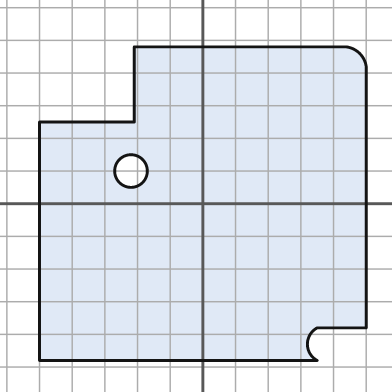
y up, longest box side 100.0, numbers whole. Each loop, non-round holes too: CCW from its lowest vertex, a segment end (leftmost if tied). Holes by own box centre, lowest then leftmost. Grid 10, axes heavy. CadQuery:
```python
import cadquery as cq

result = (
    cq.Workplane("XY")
    .moveTo(-50.0, -48.0)
    .lineTo(35.0, -48.0)
    .threePointArc((32.0, -43.0), (35.0, -38.0))
    .lineTo(50.0, -38.0)
    .lineTo(50.0, 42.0)
    .threePointArc((48.0, 46.0), (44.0, 48.0))
    .lineTo(-21.0, 48.0)
    .lineTo(-21.0, 25.0)
    .lineTo(-50.0, 25.0)
    .close()
    .moveTo(-22.0, 10.0)
    .circle(5.0)
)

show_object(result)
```